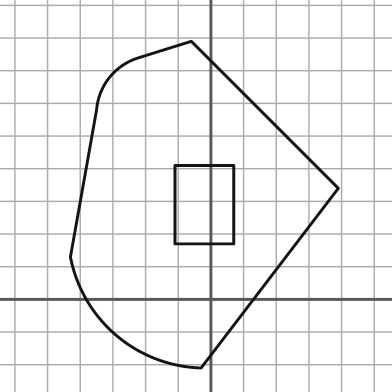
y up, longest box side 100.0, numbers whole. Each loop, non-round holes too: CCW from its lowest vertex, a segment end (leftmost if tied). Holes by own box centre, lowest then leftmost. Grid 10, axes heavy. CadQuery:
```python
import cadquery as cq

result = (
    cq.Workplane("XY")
    .moveTo(-3.0, -21.0)
    .lineTo(39.0, 34.0)
    .lineTo(-6.0, 79.0)
    .lineTo(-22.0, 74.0)
    .threePointArc((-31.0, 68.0), (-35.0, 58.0))
    .lineTo(-43.0, 13.0)
    .threePointArc((-29.0, -11.0), (-3.0, -21.0))
    .close()
    .moveTo(-11.0, 17.0)
    .lineTo(7.0, 17.0)
    .lineTo(7.0, 41.0)
    .lineTo(-11.0, 41.0)
    .close()
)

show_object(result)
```